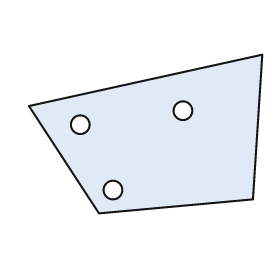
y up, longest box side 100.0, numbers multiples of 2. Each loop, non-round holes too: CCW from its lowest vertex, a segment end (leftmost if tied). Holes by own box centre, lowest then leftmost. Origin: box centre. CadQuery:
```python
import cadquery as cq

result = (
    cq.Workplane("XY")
    .moveTo(-20.0, -34.0)
    .lineTo(46.0, -28.0)
    .lineTo(50.0, 34.0)
    .lineTo(-50.0, 12.0)
    .close()
    .moveTo(-14.0, -24.0)
    .circle(4.0)
    .moveTo(-28.0, 4.0)
    .circle(4.0)
    .moveTo(16.0, 10.0)
    .circle(4.0)
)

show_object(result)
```